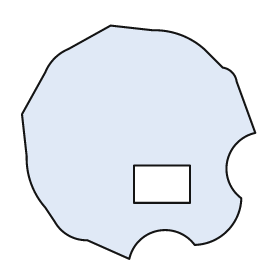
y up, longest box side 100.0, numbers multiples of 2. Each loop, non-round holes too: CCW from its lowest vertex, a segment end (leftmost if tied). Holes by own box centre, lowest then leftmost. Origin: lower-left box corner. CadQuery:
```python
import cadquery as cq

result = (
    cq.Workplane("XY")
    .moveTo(46.0, 0.0)
    .threePointArc((58.0, 12.0), (74.0, 6.0))
    .threePointArc((88.0, 12.0), (94.0, 26.0))
    .threePointArc((88.0, 42.0), (100.0, 54.0))
    .lineTo(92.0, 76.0)
    .threePointArc((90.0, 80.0), (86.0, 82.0))
    .lineTo(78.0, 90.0)
    .threePointArc((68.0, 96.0), (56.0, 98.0))
    .lineTo(38.0, 100.0)
    .lineTo(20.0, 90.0)
    .threePointArc((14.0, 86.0), (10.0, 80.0))
    .lineTo(0.0, 62.0)
    .lineTo(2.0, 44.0)
    .threePointArc((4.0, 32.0), (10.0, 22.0))
    .lineTo(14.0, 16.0)
    .threePointArc((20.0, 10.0), (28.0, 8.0))
    .close()
    .moveTo(48.0, 24.0)
    .lineTo(72.0, 24.0)
    .lineTo(72.0, 40.0)
    .lineTo(48.0, 40.0)
    .close()
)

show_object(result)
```